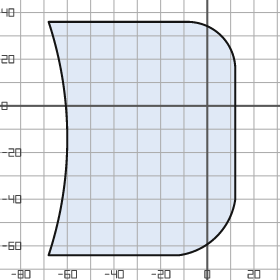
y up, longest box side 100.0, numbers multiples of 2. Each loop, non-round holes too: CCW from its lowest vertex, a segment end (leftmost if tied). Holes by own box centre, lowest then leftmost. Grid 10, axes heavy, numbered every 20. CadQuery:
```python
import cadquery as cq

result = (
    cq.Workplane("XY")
    .moveTo(-68.0, -64.0)
    .lineTo(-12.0, -64.0)
    .threePointArc((4.0, -56.0), (12.0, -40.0))
    .lineTo(12.0, 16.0)
    .threePointArc((6.0, 30.0), (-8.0, 36.0))
    .lineTo(-68.0, 36.0)
    .threePointArc((-60.0, -14.0), (-68.0, -64.0))
    .close()
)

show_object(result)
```